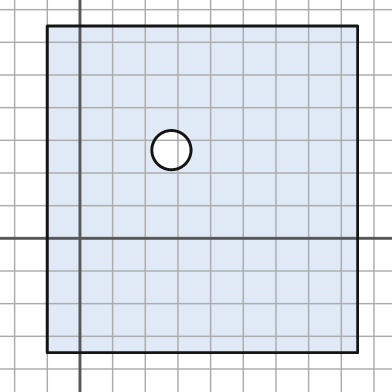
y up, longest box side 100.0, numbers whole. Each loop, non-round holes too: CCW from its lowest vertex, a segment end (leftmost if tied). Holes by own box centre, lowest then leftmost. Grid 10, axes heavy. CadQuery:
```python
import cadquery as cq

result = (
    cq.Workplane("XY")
    .moveTo(-10.0, -35.0)
    .lineTo(85.0, -35.0)
    .lineTo(85.0, 65.0)
    .lineTo(-10.0, 65.0)
    .close()
    .moveTo(28.0, 27.0)
    .circle(6.0)
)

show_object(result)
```